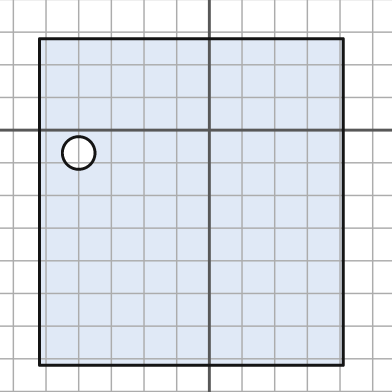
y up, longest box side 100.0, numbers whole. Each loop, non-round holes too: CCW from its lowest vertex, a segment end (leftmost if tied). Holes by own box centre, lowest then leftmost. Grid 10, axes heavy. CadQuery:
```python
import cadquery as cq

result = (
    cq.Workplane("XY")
    .moveTo(-52.0, -72.0)
    .lineTo(41.0, -72.0)
    .lineTo(41.0, 28.0)
    .lineTo(-52.0, 28.0)
    .close()
    .moveTo(-40.0, -7.0)
    .circle(5.0)
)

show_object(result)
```